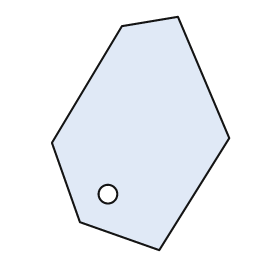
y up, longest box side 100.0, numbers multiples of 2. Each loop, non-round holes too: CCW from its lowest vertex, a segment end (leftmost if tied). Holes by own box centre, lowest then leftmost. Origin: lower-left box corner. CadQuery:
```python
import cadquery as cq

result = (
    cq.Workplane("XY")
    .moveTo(46.0, 0.0)
    .lineTo(76.0, 48.0)
    .lineTo(54.0, 100.0)
    .lineTo(30.0, 96.0)
    .lineTo(0.0, 46.0)
    .lineTo(12.0, 12.0)
    .close()
    .moveTo(24.0, 24.0)
    .circle(4.0)
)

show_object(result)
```